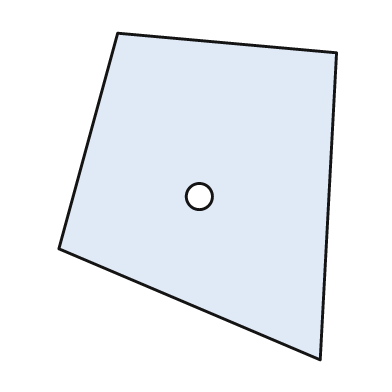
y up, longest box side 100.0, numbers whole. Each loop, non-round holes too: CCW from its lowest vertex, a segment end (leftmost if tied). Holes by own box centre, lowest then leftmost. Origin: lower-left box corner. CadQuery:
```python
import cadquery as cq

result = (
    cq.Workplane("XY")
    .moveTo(80.0, 0.0)
    .lineTo(85.0, 94.0)
    .lineTo(18.0, 100.0)
    .lineTo(0.0, 34.0)
    .close()
    .moveTo(43.0, 50.0)
    .circle(4.0)
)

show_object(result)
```